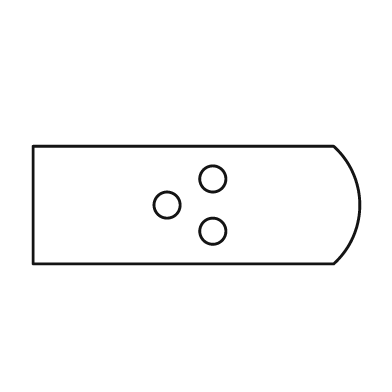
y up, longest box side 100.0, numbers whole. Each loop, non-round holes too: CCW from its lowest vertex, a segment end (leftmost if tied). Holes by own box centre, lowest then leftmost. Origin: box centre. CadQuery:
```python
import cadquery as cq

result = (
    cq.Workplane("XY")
    .moveTo(-50.0, -18.0)
    .lineTo(42.0, -18.0)
    .threePointArc((50.0, 0.0), (42.0, 18.0))
    .lineTo(-50.0, 18.0)
    .close()
    .moveTo(5.0, -8.0)
    .circle(4.0)
    .moveTo(-9.0, 0.0)
    .circle(4.0)
    .moveTo(5.0, 8.0)
    .circle(4.0)
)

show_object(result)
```